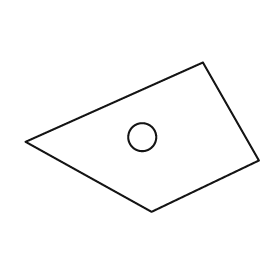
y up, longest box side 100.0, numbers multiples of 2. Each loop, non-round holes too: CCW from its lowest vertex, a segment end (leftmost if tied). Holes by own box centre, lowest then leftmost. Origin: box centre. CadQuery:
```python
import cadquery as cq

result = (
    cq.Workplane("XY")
    .moveTo(4.0, -32.0)
    .lineTo(50.0, -10.0)
    .lineTo(26.0, 32.0)
    .lineTo(-50.0, -2.0)
    .close()
    .moveTo(0.0, 0.0)
    .circle(6.0)
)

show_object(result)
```